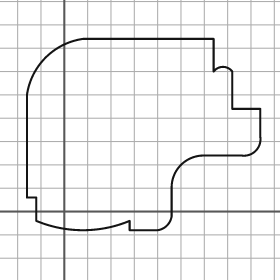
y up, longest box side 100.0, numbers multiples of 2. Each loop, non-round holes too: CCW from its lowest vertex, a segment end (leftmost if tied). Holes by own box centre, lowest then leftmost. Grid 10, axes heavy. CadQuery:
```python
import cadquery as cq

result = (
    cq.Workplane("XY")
    .moveTo(28.0, -8.0)
    .lineTo(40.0, -8.0)
    .threePointArc((44.0, -6.0), (46.0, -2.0))
    .lineTo(46.0, 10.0)
    .threePointArc((50.0, 20.0), (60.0, 24.0))
    .lineTo(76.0, 24.0)
    .threePointArc((82.0, 26.0), (84.0, 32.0))
    .lineTo(84.0, 44.0)
    .lineTo(72.0, 44.0)
    .lineTo(72.0, 60.0)
    .threePointArc((68.0, 62.0), (64.0, 60.0))
    .lineTo(64.0, 74.0)
    .lineTo(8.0, 74.0)
    .threePointArc((-8.0, 66.0), (-16.0, 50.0))
    .lineTo(-16.0, 6.0)
    .lineTo(-12.0, 6.0)
    .lineTo(-12.0, -4.0)
    .threePointArc((8.0, -8.0), (28.0, -4.0))
    .close()
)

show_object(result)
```